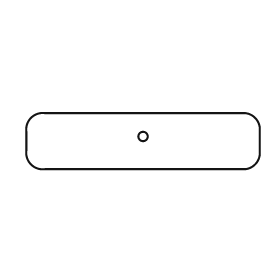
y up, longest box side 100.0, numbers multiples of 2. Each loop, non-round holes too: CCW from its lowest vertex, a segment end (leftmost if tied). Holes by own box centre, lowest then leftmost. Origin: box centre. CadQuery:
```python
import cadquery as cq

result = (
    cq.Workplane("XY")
    .moveTo(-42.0, -12.0)
    .lineTo(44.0, -12.0)
    .threePointArc((48.0, -10.0), (50.0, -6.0))
    .lineTo(50.0, 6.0)
    .threePointArc((48.0, 10.0), (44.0, 12.0))
    .lineTo(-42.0, 12.0)
    .threePointArc((-48.0, 10.0), (-50.0, 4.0))
    .lineTo(-50.0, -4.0)
    .threePointArc((-48.0, -10.0), (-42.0, -12.0))
    .close()
    .moveTo(0.0, 2.0)
    .circle(2.0)
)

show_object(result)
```